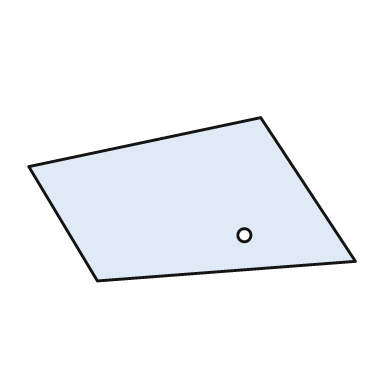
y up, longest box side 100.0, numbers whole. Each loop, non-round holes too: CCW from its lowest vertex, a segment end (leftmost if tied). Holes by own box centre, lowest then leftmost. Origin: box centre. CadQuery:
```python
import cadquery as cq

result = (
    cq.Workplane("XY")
    .moveTo(-29.0, -25.0)
    .lineTo(50.0, -19.0)
    .lineTo(21.0, 25.0)
    .lineTo(-50.0, 10.0)
    .close()
    .moveTo(16.0, -11.0)
    .circle(2.0)
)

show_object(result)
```